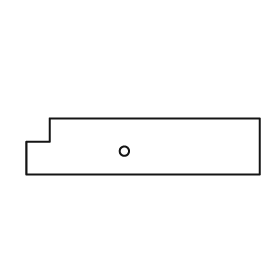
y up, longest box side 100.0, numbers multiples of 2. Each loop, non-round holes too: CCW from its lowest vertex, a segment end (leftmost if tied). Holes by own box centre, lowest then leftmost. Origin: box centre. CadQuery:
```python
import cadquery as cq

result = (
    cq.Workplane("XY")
    .moveTo(-50.0, -12.0)
    .lineTo(50.0, -12.0)
    .lineTo(50.0, 12.0)
    .lineTo(-40.0, 12.0)
    .lineTo(-40.0, 2.0)
    .lineTo(-50.0, 2.0)
    .close()
    .moveTo(-8.0, -2.0)
    .circle(2.0)
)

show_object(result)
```